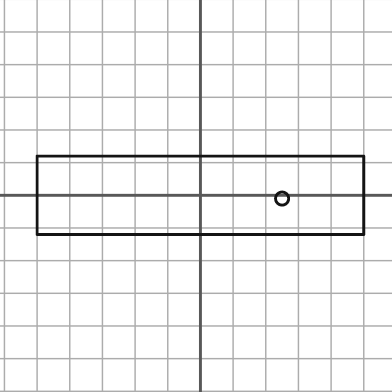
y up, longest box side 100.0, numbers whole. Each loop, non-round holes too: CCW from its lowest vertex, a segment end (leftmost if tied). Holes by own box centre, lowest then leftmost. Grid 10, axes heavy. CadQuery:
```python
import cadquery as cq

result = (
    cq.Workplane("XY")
    .moveTo(-50.0, -12.0)
    .lineTo(50.0, -12.0)
    .lineTo(50.0, 12.0)
    .lineTo(-50.0, 12.0)
    .close()
    .moveTo(25.0, -1.0)
    .circle(2.0)
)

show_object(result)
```